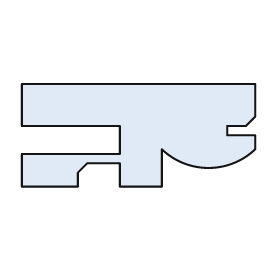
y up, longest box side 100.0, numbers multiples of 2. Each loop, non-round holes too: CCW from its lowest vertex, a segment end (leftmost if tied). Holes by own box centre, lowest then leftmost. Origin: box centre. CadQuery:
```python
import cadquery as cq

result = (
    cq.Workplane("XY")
    .moveTo(-50.0, -22.0)
    .lineTo(-26.0, -22.0)
    .lineTo(-26.0, -16.0)
    .lineTo(-22.0, -12.0)
    .lineTo(-8.0, -12.0)
    .lineTo(-8.0, -22.0)
    .lineTo(10.0, -22.0)
    .lineTo(10.0, -6.0)
    .threePointArc((30.0, -14.0), (50.0, -6.0))
    .lineTo(50.0, 0.0)
    .lineTo(38.0, 0.0)
    .lineTo(38.0, 4.0)
    .lineTo(46.0, 4.0)
    .lineTo(50.0, 8.0)
    .lineTo(50.0, 22.0)
    .lineTo(-50.0, 22.0)
    .lineTo(-50.0, 4.0)
    .lineTo(-8.0, 4.0)
    .lineTo(-8.0, -8.0)
    .lineTo(-50.0, -8.0)
    .close()
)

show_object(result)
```